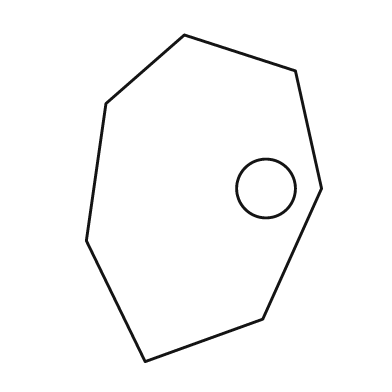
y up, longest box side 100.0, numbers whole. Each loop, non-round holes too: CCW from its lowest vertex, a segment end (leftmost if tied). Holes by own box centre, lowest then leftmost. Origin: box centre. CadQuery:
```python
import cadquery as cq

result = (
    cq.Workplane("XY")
    .moveTo(-18.0, -50.0)
    .lineTo(18.0, -37.0)
    .lineTo(36.0, 3.0)
    .lineTo(28.0, 39.0)
    .lineTo(-6.0, 50.0)
    .lineTo(-30.0, 29.0)
    .lineTo(-36.0, -13.0)
    .close()
    .moveTo(19.0, 3.0)
    .circle(9.0)
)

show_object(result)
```